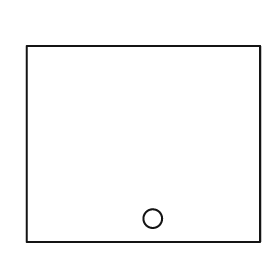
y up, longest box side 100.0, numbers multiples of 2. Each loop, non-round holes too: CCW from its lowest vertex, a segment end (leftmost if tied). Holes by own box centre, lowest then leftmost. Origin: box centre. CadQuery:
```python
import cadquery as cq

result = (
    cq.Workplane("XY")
    .moveTo(-50.0, -42.0)
    .lineTo(50.0, -42.0)
    .lineTo(50.0, 42.0)
    .lineTo(-50.0, 42.0)
    .close()
    .moveTo(4.0, -32.0)
    .circle(4.0)
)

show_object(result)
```